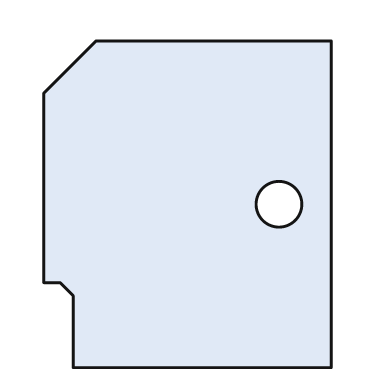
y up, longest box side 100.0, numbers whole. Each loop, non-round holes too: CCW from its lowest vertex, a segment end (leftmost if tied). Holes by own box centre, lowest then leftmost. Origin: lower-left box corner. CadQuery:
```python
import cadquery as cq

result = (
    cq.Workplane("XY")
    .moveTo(9.0, 0.0)
    .lineTo(88.0, 0.0)
    .lineTo(88.0, 100.0)
    .lineTo(16.0, 100.0)
    .lineTo(0.0, 84.0)
    .lineTo(0.0, 26.0)
    .lineTo(5.0, 26.0)
    .lineTo(9.0, 22.0)
    .close()
    .moveTo(72.0, 50.0)
    .circle(7.0)
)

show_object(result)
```